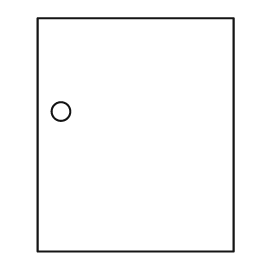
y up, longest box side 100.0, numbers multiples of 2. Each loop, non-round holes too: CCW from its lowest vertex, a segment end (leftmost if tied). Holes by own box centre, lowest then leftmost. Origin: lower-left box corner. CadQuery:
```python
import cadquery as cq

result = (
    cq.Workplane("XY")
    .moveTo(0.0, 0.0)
    .lineTo(84.0, 0.0)
    .lineTo(84.0, 100.0)
    .lineTo(0.0, 100.0)
    .close()
    .moveTo(10.0, 60.0)
    .circle(4.0)
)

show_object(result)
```